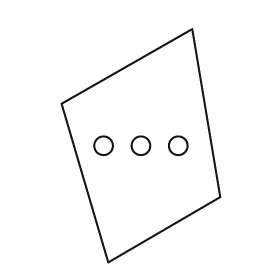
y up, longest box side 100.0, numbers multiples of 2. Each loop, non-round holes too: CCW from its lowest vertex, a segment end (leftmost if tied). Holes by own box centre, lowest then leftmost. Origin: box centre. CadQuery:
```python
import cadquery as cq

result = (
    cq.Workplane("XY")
    .moveTo(-14.0, -50.0)
    .lineTo(34.0, -22.0)
    .lineTo(22.0, 50.0)
    .lineTo(-34.0, 18.0)
    .close()
    .moveTo(-16.0, 0.0)
    .circle(4.0)
    .moveTo(0.0, 0.0)
    .circle(4.0)
    .moveTo(16.0, 0.0)
    .circle(4.0)
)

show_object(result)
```